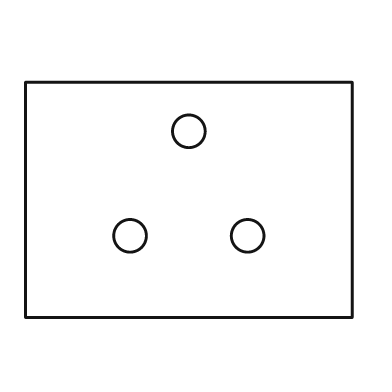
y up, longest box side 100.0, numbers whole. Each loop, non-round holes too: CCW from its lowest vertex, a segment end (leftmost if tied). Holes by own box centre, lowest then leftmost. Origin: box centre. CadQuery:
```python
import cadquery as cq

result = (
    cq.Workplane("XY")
    .moveTo(-50.0, -36.0)
    .lineTo(50.0, -36.0)
    .lineTo(50.0, 36.0)
    .lineTo(-50.0, 36.0)
    .close()
    .moveTo(-18.0, -11.0)
    .circle(5.0)
    .moveTo(18.0, -11.0)
    .circle(5.0)
    .moveTo(0.0, 21.0)
    .circle(5.0)
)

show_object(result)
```